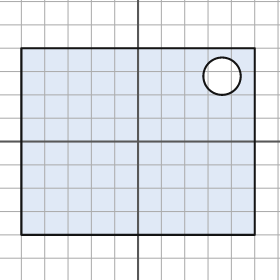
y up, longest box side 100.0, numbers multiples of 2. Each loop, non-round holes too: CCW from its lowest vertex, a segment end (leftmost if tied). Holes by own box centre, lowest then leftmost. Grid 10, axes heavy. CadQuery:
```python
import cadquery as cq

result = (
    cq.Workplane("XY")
    .moveTo(-50.0, -40.0)
    .lineTo(50.0, -40.0)
    .lineTo(50.0, 40.0)
    .lineTo(-50.0, 40.0)
    .close()
    .moveTo(36.0, 28.0)
    .circle(8.0)
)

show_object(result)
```